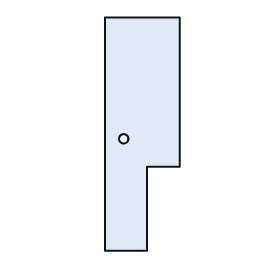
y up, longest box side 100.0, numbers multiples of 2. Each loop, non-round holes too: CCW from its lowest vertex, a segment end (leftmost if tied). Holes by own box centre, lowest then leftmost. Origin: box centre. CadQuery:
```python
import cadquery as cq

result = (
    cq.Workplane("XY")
    .moveTo(-16.0, -50.0)
    .lineTo(2.0, -50.0)
    .lineTo(2.0, -14.0)
    .lineTo(16.0, -14.0)
    .lineTo(16.0, 50.0)
    .lineTo(-16.0, 50.0)
    .close()
    .moveTo(-8.0, -2.0)
    .circle(2.0)
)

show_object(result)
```